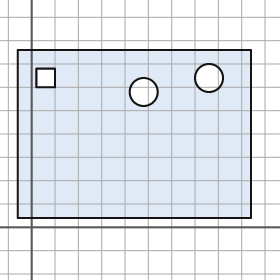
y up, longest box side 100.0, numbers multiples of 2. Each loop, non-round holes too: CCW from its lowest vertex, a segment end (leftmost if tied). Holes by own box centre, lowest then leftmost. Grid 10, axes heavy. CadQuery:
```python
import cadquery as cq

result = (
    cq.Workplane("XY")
    .moveTo(-6.0, 4.0)
    .lineTo(94.0, 4.0)
    .lineTo(94.0, 76.0)
    .lineTo(-6.0, 76.0)
    .close()
    .moveTo(48.0, 58.0)
    .circle(6.0)
    .moveTo(2.0, 60.0)
    .lineTo(10.0, 60.0)
    .lineTo(10.0, 68.0)
    .lineTo(2.0, 68.0)
    .close()
    .moveTo(76.0, 64.0)
    .circle(6.0)
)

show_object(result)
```